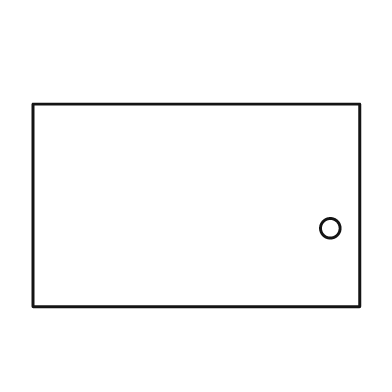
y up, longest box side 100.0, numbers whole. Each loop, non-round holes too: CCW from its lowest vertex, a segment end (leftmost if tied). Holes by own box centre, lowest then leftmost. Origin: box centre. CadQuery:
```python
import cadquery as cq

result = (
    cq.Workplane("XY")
    .moveTo(-50.0, -31.0)
    .lineTo(50.0, -31.0)
    .lineTo(50.0, 31.0)
    .lineTo(-50.0, 31.0)
    .close()
    .moveTo(41.0, -7.0)
    .circle(3.0)
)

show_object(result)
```